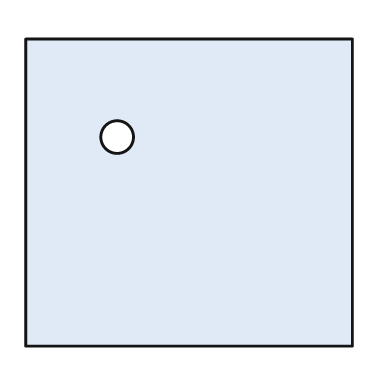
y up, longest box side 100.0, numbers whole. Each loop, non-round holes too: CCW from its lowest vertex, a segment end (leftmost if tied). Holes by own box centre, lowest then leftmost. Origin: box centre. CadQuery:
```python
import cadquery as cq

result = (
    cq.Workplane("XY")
    .moveTo(-50.0, -47.0)
    .lineTo(50.0, -47.0)
    .lineTo(50.0, 47.0)
    .lineTo(-50.0, 47.0)
    .close()
    .moveTo(-22.0, 17.0)
    .circle(5.0)
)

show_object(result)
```